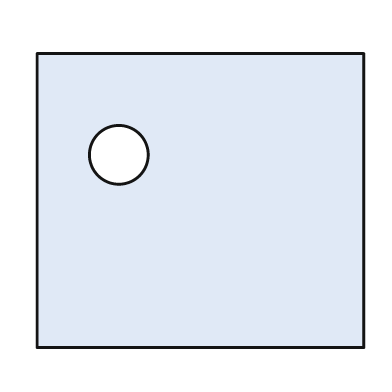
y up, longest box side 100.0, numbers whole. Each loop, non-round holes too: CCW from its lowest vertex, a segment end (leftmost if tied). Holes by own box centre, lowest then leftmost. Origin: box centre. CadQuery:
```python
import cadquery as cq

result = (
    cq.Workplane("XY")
    .moveTo(-50.0, -45.0)
    .lineTo(50.0, -45.0)
    .lineTo(50.0, 45.0)
    .lineTo(-50.0, 45.0)
    .close()
    .moveTo(-25.0, 14.0)
    .circle(9.0)
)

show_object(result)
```